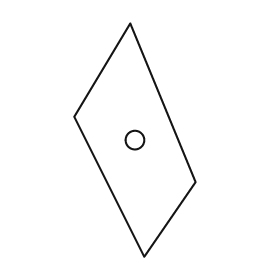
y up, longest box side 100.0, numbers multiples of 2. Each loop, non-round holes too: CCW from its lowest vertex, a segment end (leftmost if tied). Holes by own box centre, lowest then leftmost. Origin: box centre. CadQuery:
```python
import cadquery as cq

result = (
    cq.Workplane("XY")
    .moveTo(4.0, -50.0)
    .lineTo(26.0, -18.0)
    .lineTo(-2.0, 50.0)
    .lineTo(-26.0, 10.0)
    .close()
    .moveTo(0.0, 0.0)
    .circle(4.0)
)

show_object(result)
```